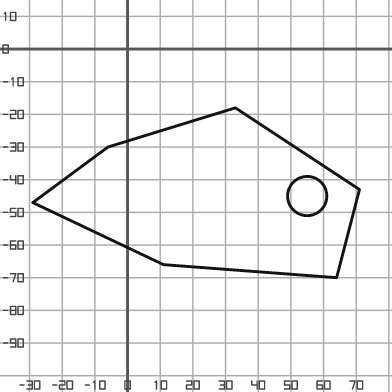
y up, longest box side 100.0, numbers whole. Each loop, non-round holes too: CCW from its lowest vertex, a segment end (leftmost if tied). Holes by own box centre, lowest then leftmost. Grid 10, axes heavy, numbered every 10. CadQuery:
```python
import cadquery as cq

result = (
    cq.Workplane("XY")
    .moveTo(64.0, -70.0)
    .lineTo(71.0, -43.0)
    .lineTo(33.0, -18.0)
    .lineTo(-6.0, -30.0)
    .lineTo(-29.0, -47.0)
    .lineTo(11.0, -66.0)
    .close()
    .moveTo(55.0, -45.0)
    .circle(6.0)
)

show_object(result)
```